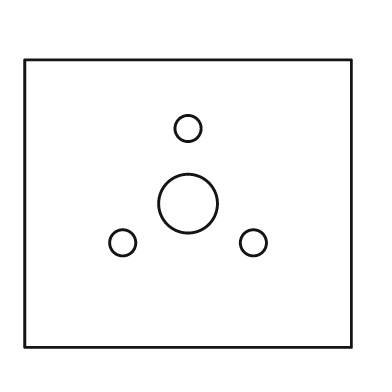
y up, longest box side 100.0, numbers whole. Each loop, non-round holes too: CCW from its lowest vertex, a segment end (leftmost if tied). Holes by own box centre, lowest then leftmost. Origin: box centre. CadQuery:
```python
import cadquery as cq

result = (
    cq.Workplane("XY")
    .moveTo(-50.0, -44.0)
    .lineTo(50.0, -44.0)
    .lineTo(50.0, 44.0)
    .lineTo(-50.0, 44.0)
    .close()
    .moveTo(-20.0, -12.0)
    .circle(4.0)
    .moveTo(20.0, -12.0)
    .circle(4.0)
    .moveTo(0.0, 0.0)
    .circle(9.0)
    .moveTo(0.0, 23.0)
    .circle(4.0)
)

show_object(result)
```